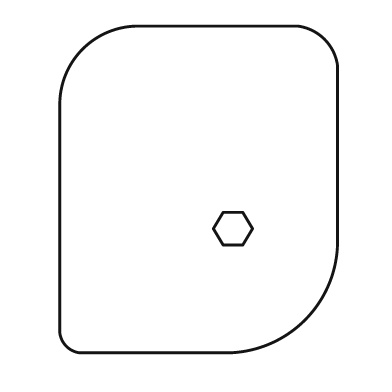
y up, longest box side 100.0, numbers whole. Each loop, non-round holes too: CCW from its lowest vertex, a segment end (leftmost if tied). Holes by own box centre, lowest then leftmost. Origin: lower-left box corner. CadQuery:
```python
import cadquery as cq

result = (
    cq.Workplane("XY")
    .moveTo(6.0, 0.0)
    .lineTo(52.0, 0.0)
    .threePointArc((75.0, 10.0), (85.0, 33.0))
    .lineTo(85.0, 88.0)
    .threePointArc((81.0, 96.0), (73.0, 100.0))
    .lineTo(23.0, 100.0)
    .threePointArc((7.0, 93.0), (0.0, 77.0))
    .lineTo(0.0, 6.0)
    .threePointArc((2.0, 2.0), (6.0, 0.0))
    .close()
    .moveTo(50.0, 33.0)
    .lineTo(56.0, 33.0)
    .lineTo(59.0, 38.0)
    .lineTo(56.0, 43.0)
    .lineTo(50.0, 43.0)
    .lineTo(47.0, 38.0)
    .close()
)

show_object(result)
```